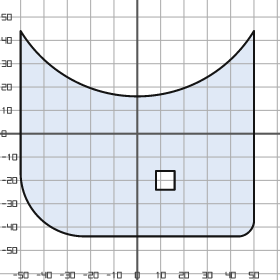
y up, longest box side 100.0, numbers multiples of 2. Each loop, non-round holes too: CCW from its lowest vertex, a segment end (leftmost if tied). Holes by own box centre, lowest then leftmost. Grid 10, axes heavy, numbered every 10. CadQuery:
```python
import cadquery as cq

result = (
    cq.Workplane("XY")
    .moveTo(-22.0, -44.0)
    .lineTo(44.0, -44.0)
    .threePointArc((48.0, -42.0), (50.0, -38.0))
    .lineTo(50.0, 44.0)
    .threePointArc((0.0, 16.0), (-50.0, 44.0))
    .lineTo(-50.0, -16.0)
    .threePointArc((-42.0, -36.0), (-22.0, -44.0))
    .close()
    .moveTo(8.0, -24.0)
    .lineTo(16.0, -24.0)
    .lineTo(16.0, -16.0)
    .lineTo(8.0, -16.0)
    .close()
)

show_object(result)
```